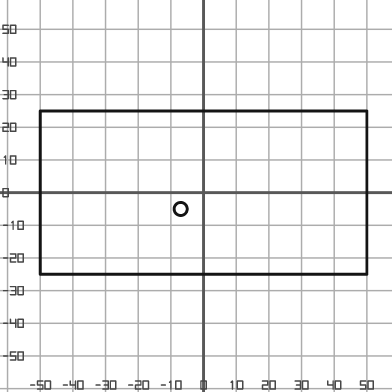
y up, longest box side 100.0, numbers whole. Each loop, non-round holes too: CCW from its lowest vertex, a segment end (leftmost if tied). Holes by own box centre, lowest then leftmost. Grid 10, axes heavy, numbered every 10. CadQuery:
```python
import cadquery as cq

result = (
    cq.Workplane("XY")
    .moveTo(-50.0, -25.0)
    .lineTo(50.0, -25.0)
    .lineTo(50.0, 25.0)
    .lineTo(-50.0, 25.0)
    .close()
    .moveTo(-7.0, -5.0)
    .circle(2.0)
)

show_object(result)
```